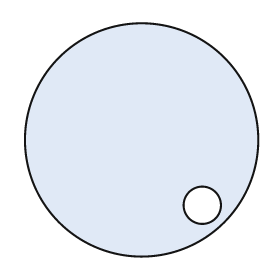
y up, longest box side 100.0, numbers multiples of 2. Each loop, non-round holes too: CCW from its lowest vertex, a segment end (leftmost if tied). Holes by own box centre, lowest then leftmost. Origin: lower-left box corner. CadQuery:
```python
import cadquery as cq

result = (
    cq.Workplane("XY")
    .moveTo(50.0, 50.0)
    .circle(50.0)
    .moveTo(76.0, 22.0)
    .circle(8.0)
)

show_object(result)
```